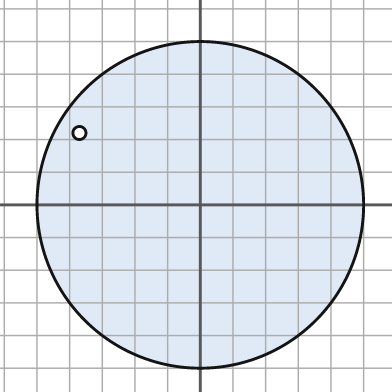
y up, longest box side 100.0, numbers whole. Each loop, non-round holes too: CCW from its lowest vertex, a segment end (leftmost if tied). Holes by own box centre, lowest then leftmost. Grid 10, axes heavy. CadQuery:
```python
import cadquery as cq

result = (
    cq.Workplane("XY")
    .moveTo(0.0, 0.0)
    .circle(50.0)
    .moveTo(-37.0, 22.0)
    .circle(2.0)
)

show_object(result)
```